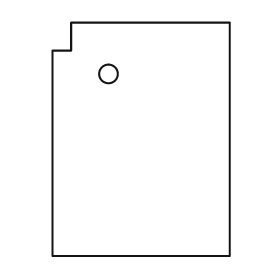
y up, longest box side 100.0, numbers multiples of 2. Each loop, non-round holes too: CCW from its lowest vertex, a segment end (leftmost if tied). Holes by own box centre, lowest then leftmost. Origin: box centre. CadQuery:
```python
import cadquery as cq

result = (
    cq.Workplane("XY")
    .moveTo(-38.0, -50.0)
    .lineTo(38.0, -50.0)
    .lineTo(38.0, 50.0)
    .lineTo(-30.0, 50.0)
    .lineTo(-30.0, 38.0)
    .lineTo(-38.0, 38.0)
    .close()
    .moveTo(-14.0, 28.0)
    .circle(4.0)
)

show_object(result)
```